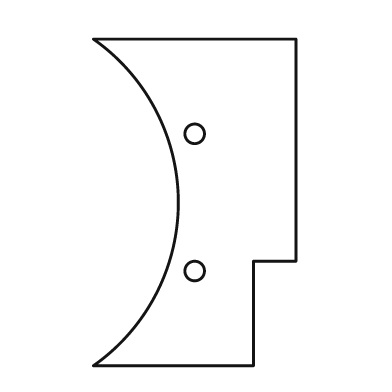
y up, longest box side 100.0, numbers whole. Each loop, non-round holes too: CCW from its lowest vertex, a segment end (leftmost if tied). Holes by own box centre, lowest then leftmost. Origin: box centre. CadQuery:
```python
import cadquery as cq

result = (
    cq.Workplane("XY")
    .moveTo(-31.0, -50.0)
    .lineTo(18.0, -50.0)
    .lineTo(18.0, -18.0)
    .lineTo(31.0, -18.0)
    .lineTo(31.0, 50.0)
    .lineTo(-31.0, 50.0)
    .threePointArc((-5.0, 0.0), (-31.0, -50.0))
    .close()
    .moveTo(0.0, -21.0)
    .circle(3.0)
    .moveTo(0.0, 21.0)
    .circle(3.0)
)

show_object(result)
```